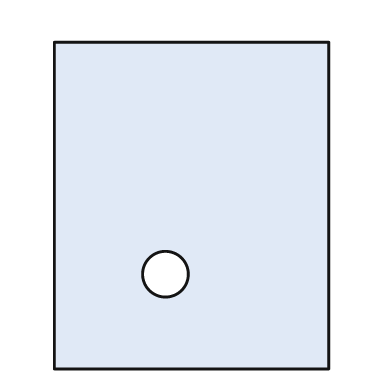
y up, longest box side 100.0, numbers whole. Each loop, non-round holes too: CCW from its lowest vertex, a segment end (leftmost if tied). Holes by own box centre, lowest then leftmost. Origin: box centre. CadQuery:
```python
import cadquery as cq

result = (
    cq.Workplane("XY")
    .moveTo(-42.0, -50.0)
    .lineTo(42.0, -50.0)
    .lineTo(42.0, 50.0)
    .lineTo(-42.0, 50.0)
    .close()
    .moveTo(-8.0, -21.0)
    .circle(7.0)
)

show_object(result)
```